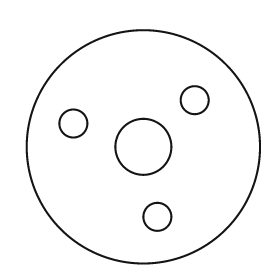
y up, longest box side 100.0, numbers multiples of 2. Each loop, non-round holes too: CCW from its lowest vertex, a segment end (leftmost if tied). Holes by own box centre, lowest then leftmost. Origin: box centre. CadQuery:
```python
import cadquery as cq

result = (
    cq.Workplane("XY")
    .moveTo(0.0, 0.0)
    .circle(50.0)
    .moveTo(6.0, -30.0)
    .circle(6.0)
    .moveTo(0.0, 0.0)
    .circle(12.0)
    .moveTo(-30.0, 10.0)
    .circle(6.0)
    .moveTo(22.0, 20.0)
    .circle(6.0)
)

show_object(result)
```